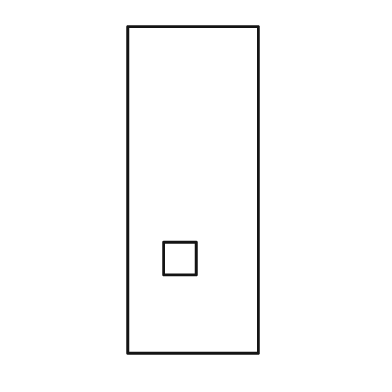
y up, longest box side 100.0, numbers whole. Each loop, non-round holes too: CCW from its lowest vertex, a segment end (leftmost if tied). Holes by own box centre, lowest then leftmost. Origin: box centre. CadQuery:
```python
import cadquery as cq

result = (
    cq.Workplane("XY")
    .moveTo(-20.0, -50.0)
    .lineTo(20.0, -50.0)
    .lineTo(20.0, 50.0)
    .lineTo(-20.0, 50.0)
    .close()
    .moveTo(-9.0, -26.0)
    .lineTo(1.0, -26.0)
    .lineTo(1.0, -16.0)
    .lineTo(-9.0, -16.0)
    .close()
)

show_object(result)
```